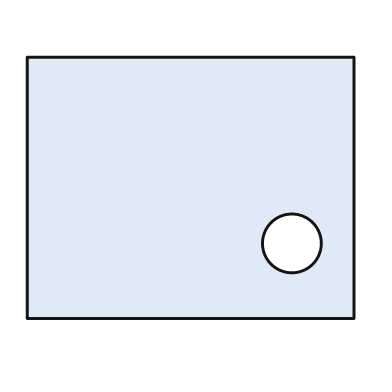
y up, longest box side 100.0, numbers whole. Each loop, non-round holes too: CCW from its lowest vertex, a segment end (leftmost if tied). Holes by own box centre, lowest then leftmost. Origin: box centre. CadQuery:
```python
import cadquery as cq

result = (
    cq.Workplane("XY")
    .moveTo(-50.0, -40.0)
    .lineTo(50.0, -40.0)
    .lineTo(50.0, 40.0)
    .lineTo(-50.0, 40.0)
    .close()
    .moveTo(31.0, -17.0)
    .circle(9.0)
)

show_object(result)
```